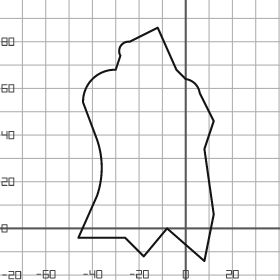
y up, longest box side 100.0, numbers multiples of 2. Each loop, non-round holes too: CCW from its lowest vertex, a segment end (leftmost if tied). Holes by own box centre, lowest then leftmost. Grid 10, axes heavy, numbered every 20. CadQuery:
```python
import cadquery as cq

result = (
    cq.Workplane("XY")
    .moveTo(8.0, -14.0)
    .lineTo(12.0, 6.0)
    .lineTo(8.0, 34.0)
    .lineTo(12.0, 46.0)
    .lineTo(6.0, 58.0)
    .threePointArc((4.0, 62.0), (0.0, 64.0))
    .lineTo(-4.0, 68.0)
    .lineTo(-12.0, 86.0)
    .lineTo(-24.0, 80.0)
    .threePointArc((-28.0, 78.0), (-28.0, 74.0))
    .lineTo(-30.0, 68.0)
    .threePointArc((-40.0, 64.0), (-44.0, 54.0))
    .lineTo(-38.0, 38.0)
    .threePointArc((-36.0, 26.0), (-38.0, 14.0))
    .lineTo(-46.0, -4.0)
    .lineTo(-26.0, -4.0)
    .lineTo(-18.0, -12.0)
    .lineTo(-8.0, 0.0)
    .close()
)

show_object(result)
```